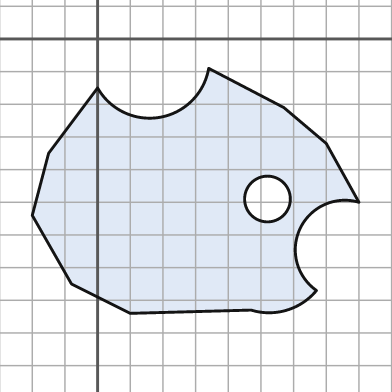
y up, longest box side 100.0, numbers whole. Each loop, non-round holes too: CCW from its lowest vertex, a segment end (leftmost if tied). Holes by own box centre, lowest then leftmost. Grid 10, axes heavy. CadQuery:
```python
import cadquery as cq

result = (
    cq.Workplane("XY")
    .moveTo(10.0, -84.0)
    .lineTo(47.0, -83.0)
    .threePointArc((58.0, -83.0), (67.0, -77.0))
    .threePointArc((62.0, -58.0), (80.0, -50.0))
    .lineTo(70.0, -32.0)
    .lineTo(57.0, -21.0)
    .lineTo(34.0, -9.0)
    .threePointArc((19.0, -24.0), (0.0, -15.0))
    .lineTo(-15.0, -35.0)
    .lineTo(-20.0, -54.0)
    .lineTo(-8.0, -75.0)
    .close()
    .moveTo(52.0, -49.0)
    .circle(7.0)
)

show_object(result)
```